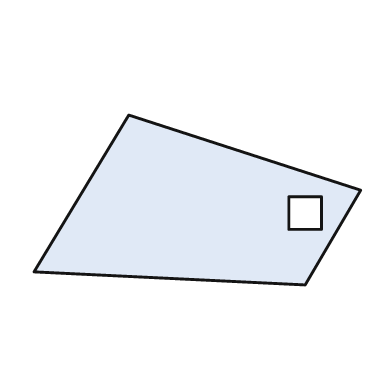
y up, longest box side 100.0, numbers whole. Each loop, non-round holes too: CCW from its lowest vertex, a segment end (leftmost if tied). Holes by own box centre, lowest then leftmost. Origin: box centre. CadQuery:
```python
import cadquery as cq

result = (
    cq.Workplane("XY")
    .moveTo(33.0, -26.0)
    .lineTo(50.0, 3.0)
    .lineTo(-21.0, 26.0)
    .lineTo(-50.0, -22.0)
    .close()
    .moveTo(28.0, -9.0)
    .lineTo(38.0, -9.0)
    .lineTo(38.0, 1.0)
    .lineTo(28.0, 1.0)
    .close()
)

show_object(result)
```